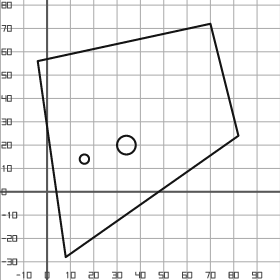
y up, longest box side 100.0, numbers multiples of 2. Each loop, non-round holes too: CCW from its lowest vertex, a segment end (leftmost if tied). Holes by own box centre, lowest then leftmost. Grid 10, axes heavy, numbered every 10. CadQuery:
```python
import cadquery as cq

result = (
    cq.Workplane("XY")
    .moveTo(8.0, -28.0)
    .lineTo(82.0, 24.0)
    .lineTo(70.0, 72.0)
    .lineTo(-4.0, 56.0)
    .close()
    .moveTo(16.0, 14.0)
    .circle(2.0)
    .moveTo(34.0, 20.0)
    .circle(4.0)
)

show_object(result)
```